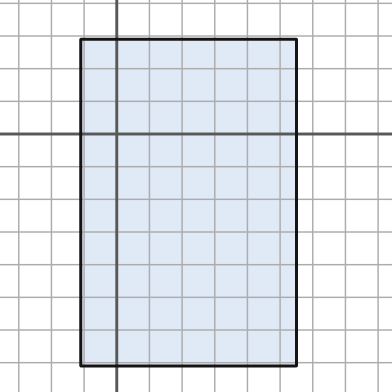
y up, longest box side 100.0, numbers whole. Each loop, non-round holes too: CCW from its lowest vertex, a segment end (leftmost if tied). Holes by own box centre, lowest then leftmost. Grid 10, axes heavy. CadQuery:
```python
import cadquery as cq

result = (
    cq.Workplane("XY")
    .moveTo(-11.0, -71.0)
    .lineTo(55.0, -71.0)
    .lineTo(55.0, 29.0)
    .lineTo(-11.0, 29.0)
    .close()
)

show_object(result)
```